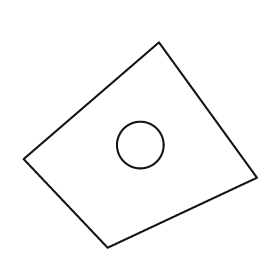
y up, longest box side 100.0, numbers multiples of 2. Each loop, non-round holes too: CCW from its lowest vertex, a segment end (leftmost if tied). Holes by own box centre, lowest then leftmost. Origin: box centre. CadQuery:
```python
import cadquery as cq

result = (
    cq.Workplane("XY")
    .moveTo(-14.0, -44.0)
    .lineTo(50.0, -14.0)
    .lineTo(8.0, 44.0)
    .lineTo(-50.0, -6.0)
    .close()
    .moveTo(0.0, 0.0)
    .circle(10.0)
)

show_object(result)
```